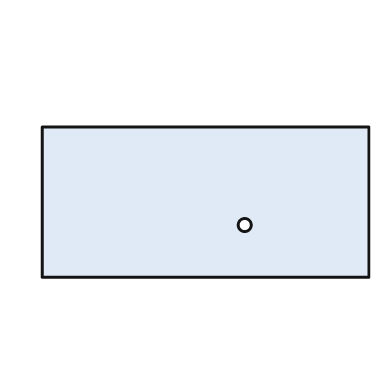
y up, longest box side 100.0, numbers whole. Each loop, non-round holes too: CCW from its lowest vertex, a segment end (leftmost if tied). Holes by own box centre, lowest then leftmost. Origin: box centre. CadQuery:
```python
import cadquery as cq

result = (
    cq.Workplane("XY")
    .moveTo(-50.0, -23.0)
    .lineTo(50.0, -23.0)
    .lineTo(50.0, 23.0)
    .lineTo(-50.0, 23.0)
    .close()
    .moveTo(12.0, -7.0)
    .circle(2.0)
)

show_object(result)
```